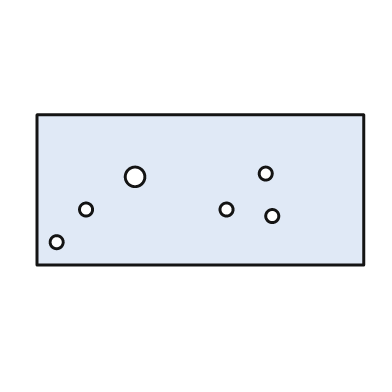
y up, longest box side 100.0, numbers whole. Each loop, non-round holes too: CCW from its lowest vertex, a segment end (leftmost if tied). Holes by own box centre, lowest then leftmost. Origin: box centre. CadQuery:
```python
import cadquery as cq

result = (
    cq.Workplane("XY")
    .moveTo(-50.0, -23.0)
    .lineTo(50.0, -23.0)
    .lineTo(50.0, 23.0)
    .lineTo(-50.0, 23.0)
    .close()
    .moveTo(-44.0, -16.0)
    .circle(2.0)
    .moveTo(22.0, -8.0)
    .circle(2.0)
    .moveTo(-35.0, -6.0)
    .circle(2.0)
    .moveTo(8.0, -6.0)
    .circle(2.0)
    .moveTo(-20.0, 4.0)
    .circle(3.0)
    .moveTo(20.0, 5.0)
    .circle(2.0)
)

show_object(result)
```